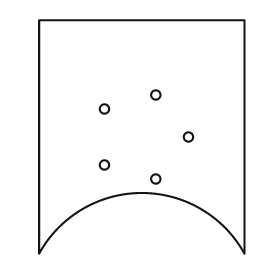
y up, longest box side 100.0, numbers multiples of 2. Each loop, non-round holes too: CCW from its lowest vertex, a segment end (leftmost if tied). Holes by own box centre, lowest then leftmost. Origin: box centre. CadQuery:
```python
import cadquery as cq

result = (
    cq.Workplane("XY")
    .moveTo(-44.0, -50.0)
    .threePointArc((0.0, -24.0), (44.0, -50.0))
    .lineTo(44.0, 50.0)
    .lineTo(-44.0, 50.0)
    .close()
    .moveTo(6.0, -18.0)
    .circle(2.0)
    .moveTo(-16.0, -12.0)
    .circle(2.0)
    .moveTo(20.0, 0.0)
    .circle(2.0)
    .moveTo(-16.0, 12.0)
    .circle(2.0)
    .moveTo(6.0, 18.0)
    .circle(2.0)
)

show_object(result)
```